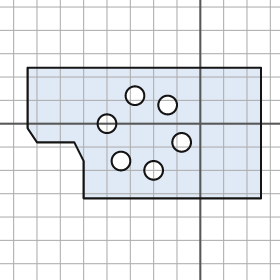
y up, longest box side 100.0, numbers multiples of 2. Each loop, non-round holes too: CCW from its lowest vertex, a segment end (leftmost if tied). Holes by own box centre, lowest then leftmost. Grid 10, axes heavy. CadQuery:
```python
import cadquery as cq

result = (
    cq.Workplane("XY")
    .moveTo(-50.0, -32.0)
    .lineTo(26.0, -32.0)
    .lineTo(26.0, 24.0)
    .lineTo(-74.0, 24.0)
    .lineTo(-74.0, -2.0)
    .lineTo(-70.0, -8.0)
    .lineTo(-54.0, -8.0)
    .lineTo(-50.0, -16.0)
    .close()
    .moveTo(-20.0, -20.0)
    .circle(4.0)
    .moveTo(-34.0, -16.0)
    .circle(4.0)
    .moveTo(-8.0, -8.0)
    .circle(4.0)
    .moveTo(-40.0, 0.0)
    .circle(4.0)
    .moveTo(-14.0, 8.0)
    .circle(4.0)
    .moveTo(-28.0, 12.0)
    .circle(4.0)
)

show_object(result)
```